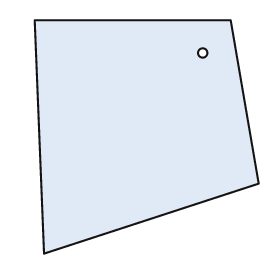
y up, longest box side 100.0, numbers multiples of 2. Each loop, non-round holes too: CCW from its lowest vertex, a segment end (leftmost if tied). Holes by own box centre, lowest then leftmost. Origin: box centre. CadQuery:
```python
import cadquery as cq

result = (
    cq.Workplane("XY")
    .moveTo(-44.0, -50.0)
    .lineTo(48.0, -20.0)
    .lineTo(36.0, 50.0)
    .lineTo(-48.0, 50.0)
    .close()
    .moveTo(24.0, 36.0)
    .circle(2.0)
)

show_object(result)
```